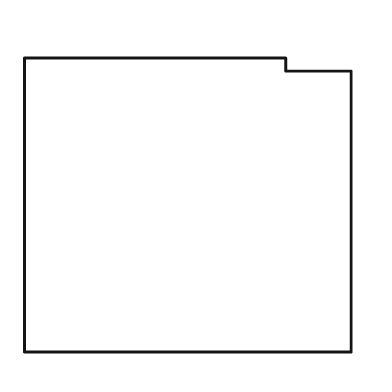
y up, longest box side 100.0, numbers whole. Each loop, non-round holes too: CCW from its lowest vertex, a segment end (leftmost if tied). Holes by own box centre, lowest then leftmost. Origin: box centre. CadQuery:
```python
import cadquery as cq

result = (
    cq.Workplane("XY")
    .moveTo(-50.0, -45.0)
    .lineTo(50.0, -45.0)
    .lineTo(50.0, 41.0)
    .lineTo(30.0, 41.0)
    .lineTo(30.0, 45.0)
    .lineTo(-50.0, 45.0)
    .close()
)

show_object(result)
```